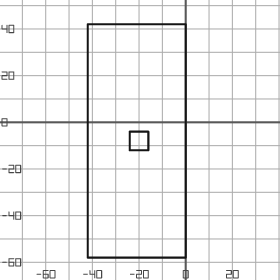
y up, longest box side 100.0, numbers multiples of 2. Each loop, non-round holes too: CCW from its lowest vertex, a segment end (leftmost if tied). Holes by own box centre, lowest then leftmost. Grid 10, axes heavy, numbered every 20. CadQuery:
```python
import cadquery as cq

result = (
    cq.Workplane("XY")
    .moveTo(-42.0, -58.0)
    .lineTo(0.0, -58.0)
    .lineTo(0.0, 42.0)
    .lineTo(-42.0, 42.0)
    .close()
    .moveTo(-24.0, -12.0)
    .lineTo(-16.0, -12.0)
    .lineTo(-16.0, -4.0)
    .lineTo(-24.0, -4.0)
    .close()
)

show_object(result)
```